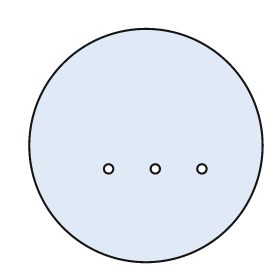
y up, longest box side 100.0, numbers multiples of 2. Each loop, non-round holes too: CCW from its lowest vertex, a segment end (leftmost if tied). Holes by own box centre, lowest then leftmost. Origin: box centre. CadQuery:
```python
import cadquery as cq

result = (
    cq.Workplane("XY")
    .moveTo(0.0, 0.0)
    .circle(50.0)
    .moveTo(-16.0, -10.0)
    .circle(2.0)
    .moveTo(4.0, -10.0)
    .circle(2.0)
    .moveTo(24.0, -10.0)
    .circle(2.0)
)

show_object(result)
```